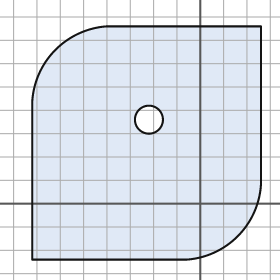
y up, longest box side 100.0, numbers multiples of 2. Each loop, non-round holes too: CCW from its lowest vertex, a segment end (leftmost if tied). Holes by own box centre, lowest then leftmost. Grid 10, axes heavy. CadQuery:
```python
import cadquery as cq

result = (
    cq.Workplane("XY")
    .moveTo(-72.0, -24.0)
    .lineTo(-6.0, -24.0)
    .threePointArc((16.0, -14.0), (26.0, 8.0))
    .lineTo(26.0, 76.0)
    .lineTo(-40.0, 76.0)
    .threePointArc((-62.0, 66.0), (-72.0, 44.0))
    .close()
    .moveTo(-22.0, 36.0)
    .circle(6.0)
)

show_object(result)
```